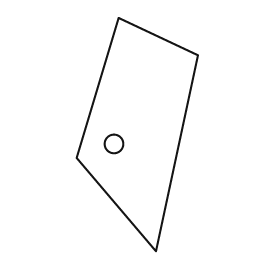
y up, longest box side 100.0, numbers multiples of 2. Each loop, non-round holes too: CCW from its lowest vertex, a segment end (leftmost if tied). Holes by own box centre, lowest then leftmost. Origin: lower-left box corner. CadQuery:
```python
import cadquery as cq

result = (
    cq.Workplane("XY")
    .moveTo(34.0, 0.0)
    .lineTo(52.0, 84.0)
    .lineTo(18.0, 100.0)
    .lineTo(0.0, 40.0)
    .close()
    .moveTo(16.0, 46.0)
    .circle(4.0)
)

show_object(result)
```